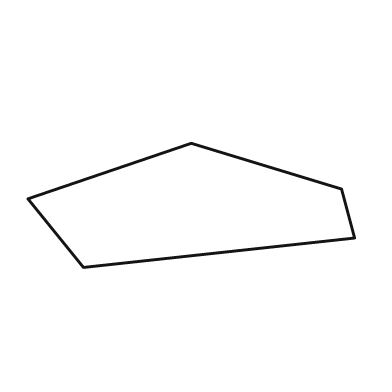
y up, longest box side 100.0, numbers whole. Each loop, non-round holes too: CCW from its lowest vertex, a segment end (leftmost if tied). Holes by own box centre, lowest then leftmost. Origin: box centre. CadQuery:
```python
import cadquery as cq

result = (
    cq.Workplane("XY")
    .moveTo(-33.0, -19.0)
    .lineTo(50.0, -10.0)
    .lineTo(46.0, 5.0)
    .lineTo(0.0, 19.0)
    .lineTo(-50.0, 2.0)
    .close()
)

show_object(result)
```